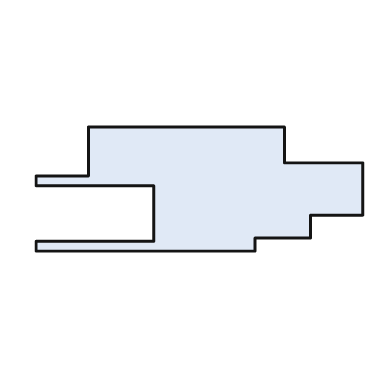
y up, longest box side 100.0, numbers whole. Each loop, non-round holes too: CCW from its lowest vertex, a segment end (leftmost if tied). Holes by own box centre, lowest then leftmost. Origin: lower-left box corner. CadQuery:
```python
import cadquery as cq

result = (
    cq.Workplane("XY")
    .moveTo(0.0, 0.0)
    .lineTo(67.0, 0.0)
    .lineTo(67.0, 4.0)
    .lineTo(84.0, 4.0)
    .lineTo(84.0, 11.0)
    .lineTo(100.0, 11.0)
    .lineTo(100.0, 27.0)
    .lineTo(76.0, 27.0)
    .lineTo(76.0, 38.0)
    .lineTo(16.0, 38.0)
    .lineTo(16.0, 23.0)
    .lineTo(0.0, 23.0)
    .lineTo(0.0, 20.0)
    .lineTo(36.0, 20.0)
    .lineTo(36.0, 3.0)
    .lineTo(0.0, 3.0)
    .close()
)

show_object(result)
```